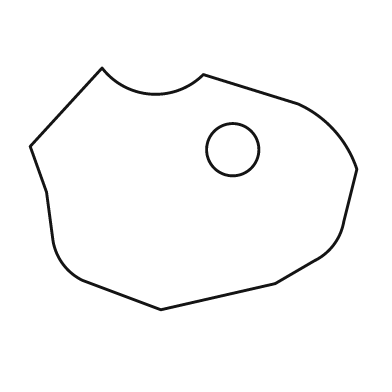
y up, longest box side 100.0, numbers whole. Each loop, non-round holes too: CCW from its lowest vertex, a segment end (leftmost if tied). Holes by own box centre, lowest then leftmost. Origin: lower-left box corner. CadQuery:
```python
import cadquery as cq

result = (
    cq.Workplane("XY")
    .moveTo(40.0, 0.0)
    .lineTo(75.0, 8.0)
    .lineTo(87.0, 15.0)
    .threePointArc((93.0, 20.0), (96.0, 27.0))
    .lineTo(100.0, 43.0)
    .threePointArc((93.0, 55.0), (82.0, 63.0))
    .lineTo(53.0, 72.0)
    .threePointArc((37.0, 66.0), (22.0, 74.0))
    .lineTo(0.0, 50.0)
    .lineTo(5.0, 36.0)
    .lineTo(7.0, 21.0)
    .threePointArc((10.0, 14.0), (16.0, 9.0))
    .close()
    .moveTo(62.0, 49.0)
    .circle(8.0)
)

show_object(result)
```